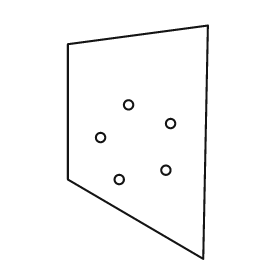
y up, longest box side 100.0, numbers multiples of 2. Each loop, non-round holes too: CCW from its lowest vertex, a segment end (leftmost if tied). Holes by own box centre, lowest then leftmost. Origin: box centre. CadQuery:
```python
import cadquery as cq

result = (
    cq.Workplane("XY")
    .moveTo(28.0, -50.0)
    .lineTo(30.0, 50.0)
    .lineTo(-30.0, 42.0)
    .lineTo(-30.0, -16.0)
    .close()
    .moveTo(-8.0, -16.0)
    .circle(2.0)
    .moveTo(12.0, -12.0)
    .circle(2.0)
    .moveTo(-16.0, 2.0)
    .circle(2.0)
    .moveTo(14.0, 8.0)
    .circle(2.0)
    .moveTo(-4.0, 16.0)
    .circle(2.0)
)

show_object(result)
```